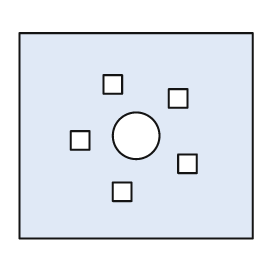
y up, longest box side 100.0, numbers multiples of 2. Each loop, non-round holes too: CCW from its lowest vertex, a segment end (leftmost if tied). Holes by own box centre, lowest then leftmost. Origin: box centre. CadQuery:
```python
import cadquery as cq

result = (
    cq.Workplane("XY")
    .moveTo(-50.0, -44.0)
    .lineTo(50.0, -44.0)
    .lineTo(50.0, 44.0)
    .lineTo(-50.0, 44.0)
    .close()
    .moveTo(-10.0, -28.0)
    .lineTo(-2.0, -28.0)
    .lineTo(-2.0, -20.0)
    .lineTo(-10.0, -20.0)
    .close()
    .moveTo(18.0, -16.0)
    .lineTo(26.0, -16.0)
    .lineTo(26.0, -8.0)
    .lineTo(18.0, -8.0)
    .close()
    .moveTo(-28.0, -6.0)
    .lineTo(-20.0, -6.0)
    .lineTo(-20.0, 2.0)
    .lineTo(-28.0, 2.0)
    .close()
    .moveTo(0.0, 0.0)
    .circle(10.0)
    .moveTo(14.0, 12.0)
    .lineTo(22.0, 12.0)
    .lineTo(22.0, 20.0)
    .lineTo(14.0, 20.0)
    .close()
    .moveTo(-14.0, 18.0)
    .lineTo(-6.0, 18.0)
    .lineTo(-6.0, 26.0)
    .lineTo(-14.0, 26.0)
    .close()
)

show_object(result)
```